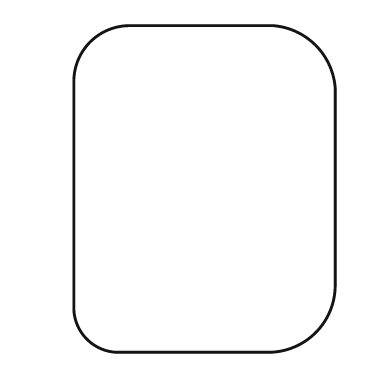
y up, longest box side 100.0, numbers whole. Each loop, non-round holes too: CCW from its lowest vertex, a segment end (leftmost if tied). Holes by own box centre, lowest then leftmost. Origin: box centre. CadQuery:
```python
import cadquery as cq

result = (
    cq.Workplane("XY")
    .moveTo(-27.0, -50.0)
    .lineTo(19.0, -50.0)
    .threePointArc((34.0, -44.0), (40.0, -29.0))
    .lineTo(40.0, 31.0)
    .threePointArc((34.0, 44.0), (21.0, 50.0))
    .lineTo(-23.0, 50.0)
    .threePointArc((-35.0, 45.0), (-40.0, 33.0))
    .lineTo(-40.0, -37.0)
    .threePointArc((-36.0, -46.0), (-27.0, -50.0))
    .close()
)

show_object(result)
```